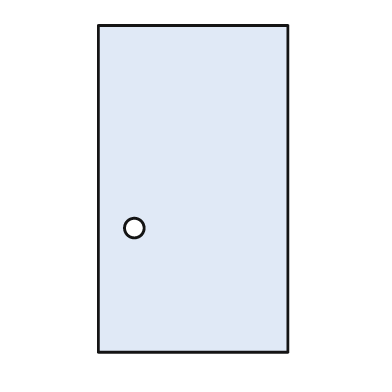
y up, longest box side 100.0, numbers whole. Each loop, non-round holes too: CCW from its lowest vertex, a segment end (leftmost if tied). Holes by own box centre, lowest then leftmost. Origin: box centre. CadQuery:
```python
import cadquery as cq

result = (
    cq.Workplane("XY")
    .moveTo(-29.0, -50.0)
    .lineTo(29.0, -50.0)
    .lineTo(29.0, 50.0)
    .lineTo(-29.0, 50.0)
    .close()
    .moveTo(-18.0, -12.0)
    .circle(3.0)
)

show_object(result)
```